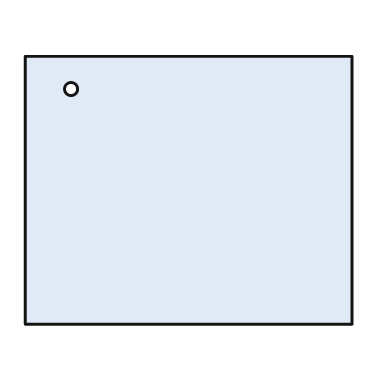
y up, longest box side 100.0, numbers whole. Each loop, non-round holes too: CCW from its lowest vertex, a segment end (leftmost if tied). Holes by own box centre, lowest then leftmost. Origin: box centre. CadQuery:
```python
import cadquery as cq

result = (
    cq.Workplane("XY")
    .moveTo(-50.0, -41.0)
    .lineTo(50.0, -41.0)
    .lineTo(50.0, 41.0)
    .lineTo(-50.0, 41.0)
    .close()
    .moveTo(-36.0, 31.0)
    .circle(2.0)
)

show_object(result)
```